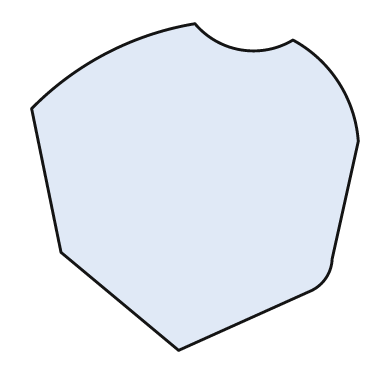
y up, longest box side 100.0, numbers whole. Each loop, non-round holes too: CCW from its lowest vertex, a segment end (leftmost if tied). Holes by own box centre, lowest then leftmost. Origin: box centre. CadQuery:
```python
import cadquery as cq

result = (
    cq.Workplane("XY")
    .moveTo(-5.0, -50.0)
    .lineTo(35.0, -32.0)
    .threePointArc((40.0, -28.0), (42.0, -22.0))
    .lineTo(50.0, 14.0)
    .threePointArc((44.0, 32.0), (30.0, 45.0))
    .threePointArc((14.0, 42.0), (0.0, 50.0))
    .threePointArc((-27.0, 41.0), (-50.0, 24.0))
    .lineTo(-41.0, -20.0)
    .close()
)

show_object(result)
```